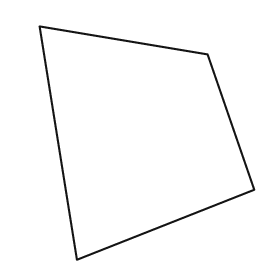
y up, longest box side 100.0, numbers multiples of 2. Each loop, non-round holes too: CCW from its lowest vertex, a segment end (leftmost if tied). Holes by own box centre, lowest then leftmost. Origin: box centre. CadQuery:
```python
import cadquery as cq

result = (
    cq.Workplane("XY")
    .moveTo(-30.0, -50.0)
    .lineTo(46.0, -20.0)
    .lineTo(26.0, 38.0)
    .lineTo(-46.0, 50.0)
    .close()
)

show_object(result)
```